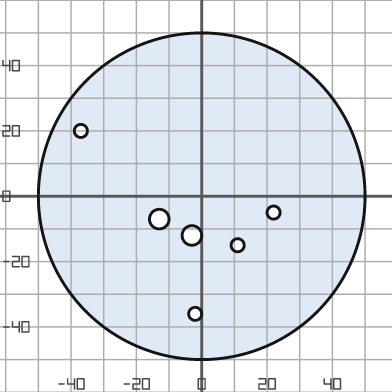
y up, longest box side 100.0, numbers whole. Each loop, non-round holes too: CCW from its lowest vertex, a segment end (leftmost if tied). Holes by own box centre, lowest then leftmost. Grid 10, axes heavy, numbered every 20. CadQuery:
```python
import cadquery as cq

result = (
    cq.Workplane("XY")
    .moveTo(0.0, 0.0)
    .circle(50.0)
    .moveTo(-2.0, -36.0)
    .circle(2.0)
    .moveTo(11.0, -15.0)
    .circle(2.0)
    .moveTo(-3.0, -12.0)
    .circle(3.0)
    .moveTo(-13.0, -7.0)
    .circle(3.0)
    .moveTo(22.0, -5.0)
    .circle(2.0)
    .moveTo(-37.0, 20.0)
    .circle(2.0)
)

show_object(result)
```